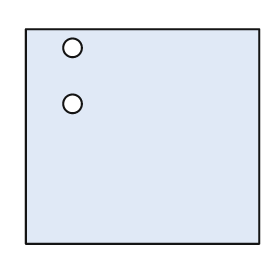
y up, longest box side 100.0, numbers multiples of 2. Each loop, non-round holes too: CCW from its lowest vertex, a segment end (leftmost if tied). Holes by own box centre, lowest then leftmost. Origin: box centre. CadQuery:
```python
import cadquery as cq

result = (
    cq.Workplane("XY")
    .moveTo(-50.0, -46.0)
    .lineTo(50.0, -46.0)
    .lineTo(50.0, 46.0)
    .lineTo(-50.0, 46.0)
    .close()
    .moveTo(-30.0, 14.0)
    .circle(4.0)
    .moveTo(-30.0, 38.0)
    .circle(4.0)
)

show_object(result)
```